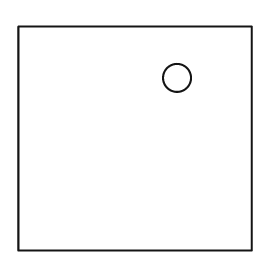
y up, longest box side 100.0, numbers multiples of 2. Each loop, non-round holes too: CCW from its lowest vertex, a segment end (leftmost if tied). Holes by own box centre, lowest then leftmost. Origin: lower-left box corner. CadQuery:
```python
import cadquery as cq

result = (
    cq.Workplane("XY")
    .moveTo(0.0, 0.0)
    .lineTo(100.0, 0.0)
    .lineTo(100.0, 96.0)
    .lineTo(0.0, 96.0)
    .close()
    .moveTo(68.0, 74.0)
    .circle(6.0)
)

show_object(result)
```